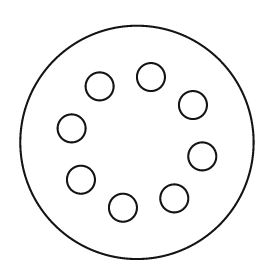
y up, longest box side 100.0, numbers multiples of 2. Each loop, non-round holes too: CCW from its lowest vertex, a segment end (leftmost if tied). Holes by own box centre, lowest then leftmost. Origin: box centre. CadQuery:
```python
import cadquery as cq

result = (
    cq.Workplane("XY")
    .moveTo(0.0, 0.0)
    .circle(50.0)
    .moveTo(-6.0, -28.0)
    .circle(6.0)
    .moveTo(16.0, -24.0)
    .circle(6.0)
    .moveTo(-24.0, -16.0)
    .circle(6.0)
    .moveTo(28.0, -6.0)
    .circle(6.0)
    .moveTo(-28.0, 6.0)
    .circle(6.0)
    .moveTo(24.0, 16.0)
    .circle(6.0)
    .moveTo(-16.0, 24.0)
    .circle(6.0)
    .moveTo(6.0, 28.0)
    .circle(6.0)
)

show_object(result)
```